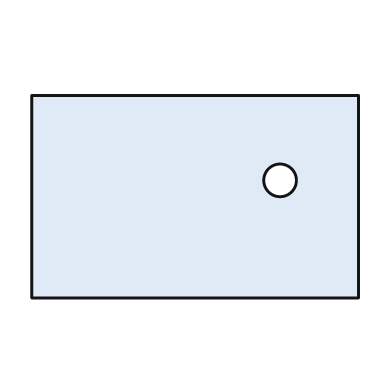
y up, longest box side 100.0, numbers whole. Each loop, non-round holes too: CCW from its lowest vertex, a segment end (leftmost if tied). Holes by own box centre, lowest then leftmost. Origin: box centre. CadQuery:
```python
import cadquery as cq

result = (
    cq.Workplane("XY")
    .moveTo(-50.0, -31.0)
    .lineTo(50.0, -31.0)
    .lineTo(50.0, 31.0)
    .lineTo(-50.0, 31.0)
    .close()
    .moveTo(26.0, 5.0)
    .circle(5.0)
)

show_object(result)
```